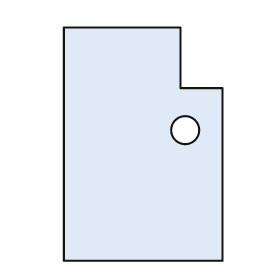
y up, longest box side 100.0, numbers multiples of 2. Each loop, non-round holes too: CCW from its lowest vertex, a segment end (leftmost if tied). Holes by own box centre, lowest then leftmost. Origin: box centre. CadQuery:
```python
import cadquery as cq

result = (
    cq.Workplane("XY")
    .moveTo(-34.0, -50.0)
    .lineTo(34.0, -50.0)
    .lineTo(34.0, 24.0)
    .lineTo(16.0, 24.0)
    .lineTo(16.0, 50.0)
    .lineTo(-34.0, 50.0)
    .close()
    .moveTo(18.0, 6.0)
    .circle(6.0)
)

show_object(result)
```